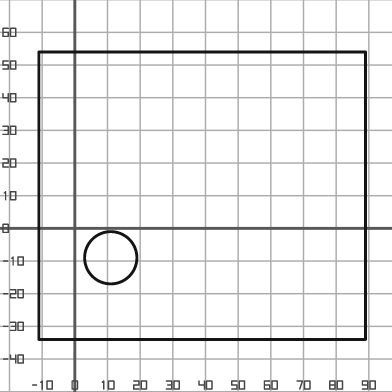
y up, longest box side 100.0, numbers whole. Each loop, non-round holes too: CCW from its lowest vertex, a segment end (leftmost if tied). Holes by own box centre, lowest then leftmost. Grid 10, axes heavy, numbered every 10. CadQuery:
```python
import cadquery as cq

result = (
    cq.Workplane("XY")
    .moveTo(-11.0, -34.0)
    .lineTo(89.0, -34.0)
    .lineTo(89.0, 54.0)
    .lineTo(-11.0, 54.0)
    .close()
    .moveTo(11.0, -9.0)
    .circle(8.0)
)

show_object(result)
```